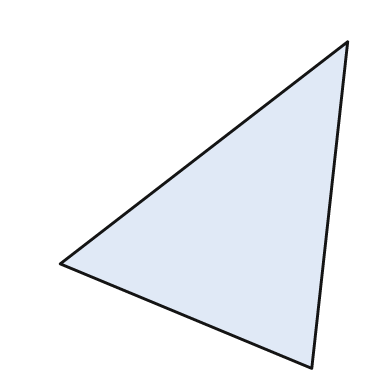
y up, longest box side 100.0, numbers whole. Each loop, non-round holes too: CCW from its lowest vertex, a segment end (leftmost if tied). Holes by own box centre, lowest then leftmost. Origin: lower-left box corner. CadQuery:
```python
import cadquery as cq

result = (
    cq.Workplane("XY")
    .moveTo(77.0, 0.0)
    .lineTo(88.0, 100.0)
    .lineTo(0.0, 32.0)
    .close()
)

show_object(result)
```